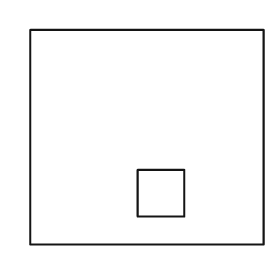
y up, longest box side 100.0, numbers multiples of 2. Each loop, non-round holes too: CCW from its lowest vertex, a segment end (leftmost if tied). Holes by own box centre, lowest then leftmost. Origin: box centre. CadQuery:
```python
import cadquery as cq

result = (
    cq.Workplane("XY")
    .moveTo(-50.0, -46.0)
    .lineTo(50.0, -46.0)
    .lineTo(50.0, 46.0)
    .lineTo(-50.0, 46.0)
    .close()
    .moveTo(-4.0, -34.0)
    .lineTo(16.0, -34.0)
    .lineTo(16.0, -14.0)
    .lineTo(-4.0, -14.0)
    .close()
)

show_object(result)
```